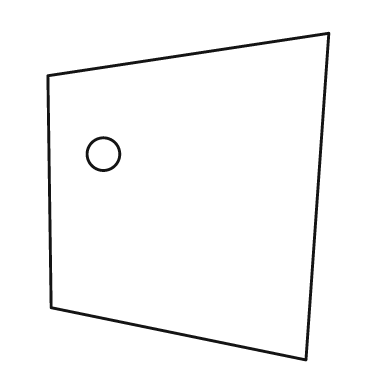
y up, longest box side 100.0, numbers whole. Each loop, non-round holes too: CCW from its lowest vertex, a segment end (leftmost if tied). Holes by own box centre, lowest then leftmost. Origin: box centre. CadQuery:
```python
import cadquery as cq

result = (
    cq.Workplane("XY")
    .moveTo(36.0, -50.0)
    .lineTo(43.0, 50.0)
    .lineTo(-43.0, 37.0)
    .lineTo(-42.0, -34.0)
    .close()
    .moveTo(-26.0, 13.0)
    .circle(5.0)
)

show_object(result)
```